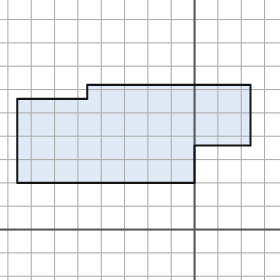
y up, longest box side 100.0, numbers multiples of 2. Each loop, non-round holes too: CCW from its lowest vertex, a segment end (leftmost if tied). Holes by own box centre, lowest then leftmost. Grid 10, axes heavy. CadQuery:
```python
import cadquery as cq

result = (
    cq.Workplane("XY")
    .moveTo(-76.0, 20.0)
    .lineTo(0.0, 20.0)
    .lineTo(0.0, 36.0)
    .lineTo(24.0, 36.0)
    .lineTo(24.0, 62.0)
    .lineTo(-46.0, 62.0)
    .lineTo(-46.0, 56.0)
    .lineTo(-76.0, 56.0)
    .close()
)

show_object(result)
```